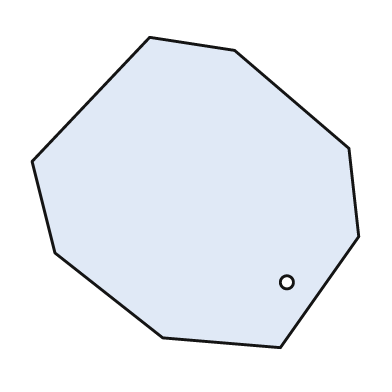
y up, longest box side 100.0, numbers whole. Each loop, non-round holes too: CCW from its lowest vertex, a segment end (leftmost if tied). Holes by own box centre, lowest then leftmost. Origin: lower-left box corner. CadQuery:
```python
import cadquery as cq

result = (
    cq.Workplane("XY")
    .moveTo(76.0, 0.0)
    .lineTo(100.0, 34.0)
    .lineTo(97.0, 61.0)
    .lineTo(62.0, 91.0)
    .lineTo(36.0, 95.0)
    .lineTo(0.0, 57.0)
    .lineTo(7.0, 29.0)
    .lineTo(40.0, 3.0)
    .close()
    .moveTo(78.0, 20.0)
    .circle(2.0)
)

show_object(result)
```